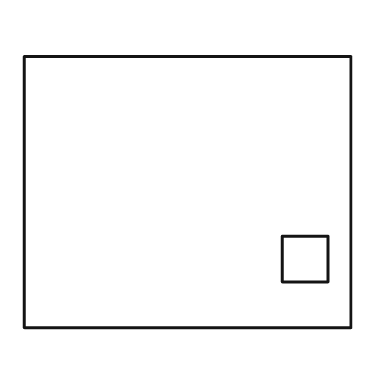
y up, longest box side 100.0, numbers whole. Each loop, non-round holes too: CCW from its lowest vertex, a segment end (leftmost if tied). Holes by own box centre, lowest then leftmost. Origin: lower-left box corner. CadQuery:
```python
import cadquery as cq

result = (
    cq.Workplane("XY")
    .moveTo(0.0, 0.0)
    .lineTo(100.0, 0.0)
    .lineTo(100.0, 83.0)
    .lineTo(0.0, 83.0)
    .close()
    .moveTo(79.0, 14.0)
    .lineTo(93.0, 14.0)
    .lineTo(93.0, 28.0)
    .lineTo(79.0, 28.0)
    .close()
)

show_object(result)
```